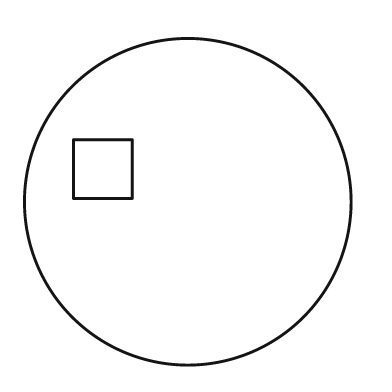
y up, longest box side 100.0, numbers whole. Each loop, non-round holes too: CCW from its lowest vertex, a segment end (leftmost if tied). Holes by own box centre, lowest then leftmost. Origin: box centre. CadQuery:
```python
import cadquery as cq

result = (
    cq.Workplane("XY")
    .moveTo(0.0, 0.0)
    .circle(50.0)
    .moveTo(-35.0, 1.0)
    .lineTo(-17.0, 1.0)
    .lineTo(-17.0, 19.0)
    .lineTo(-35.0, 19.0)
    .close()
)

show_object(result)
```